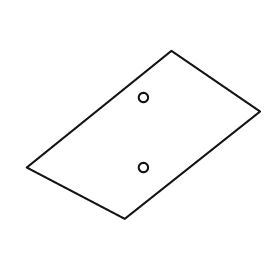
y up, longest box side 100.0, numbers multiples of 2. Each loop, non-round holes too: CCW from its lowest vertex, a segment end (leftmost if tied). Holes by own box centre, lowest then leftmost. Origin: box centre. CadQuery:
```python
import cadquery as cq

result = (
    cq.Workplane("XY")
    .moveTo(-8.0, -36.0)
    .lineTo(50.0, 10.0)
    .lineTo(12.0, 36.0)
    .lineTo(-50.0, -14.0)
    .close()
    .moveTo(0.0, -14.0)
    .circle(2.0)
    .moveTo(0.0, 16.0)
    .circle(2.0)
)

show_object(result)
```